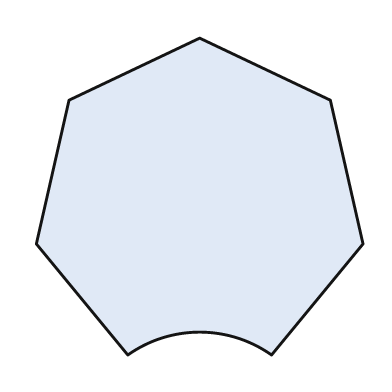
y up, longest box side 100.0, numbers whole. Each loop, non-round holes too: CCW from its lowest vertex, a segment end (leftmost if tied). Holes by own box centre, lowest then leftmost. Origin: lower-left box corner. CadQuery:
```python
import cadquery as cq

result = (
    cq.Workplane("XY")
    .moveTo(28.0, 0.0)
    .threePointArc((50.0, 7.0), (72.0, 0.0))
    .lineTo(100.0, 34.0)
    .lineTo(90.0, 78.0)
    .lineTo(50.0, 97.0)
    .lineTo(10.0, 78.0)
    .lineTo(0.0, 34.0)
    .close()
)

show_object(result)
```